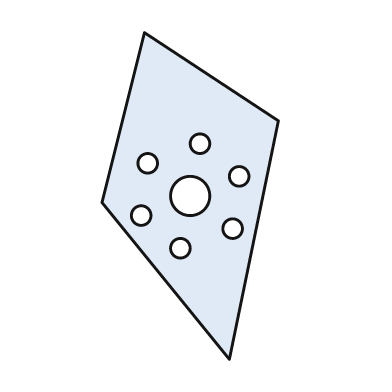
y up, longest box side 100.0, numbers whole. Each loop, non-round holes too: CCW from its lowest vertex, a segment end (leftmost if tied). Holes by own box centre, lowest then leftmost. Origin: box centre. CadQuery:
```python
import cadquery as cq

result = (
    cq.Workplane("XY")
    .moveTo(12.0, -50.0)
    .lineTo(27.0, 23.0)
    .lineTo(-14.0, 50.0)
    .lineTo(-27.0, -2.0)
    .close()
    .moveTo(-3.0, -16.0)
    .circle(3.0)
    .moveTo(13.0, -10.0)
    .circle(3.0)
    .moveTo(-15.0, -6.0)
    .circle(3.0)
    .moveTo(0.0, 0.0)
    .circle(6.0)
    .moveTo(15.0, 6.0)
    .circle(3.0)
    .moveTo(-13.0, 10.0)
    .circle(3.0)
    .moveTo(3.0, 16.0)
    .circle(3.0)
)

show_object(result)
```